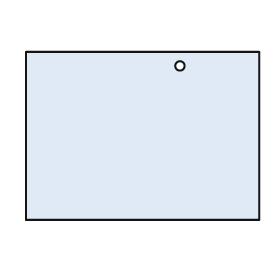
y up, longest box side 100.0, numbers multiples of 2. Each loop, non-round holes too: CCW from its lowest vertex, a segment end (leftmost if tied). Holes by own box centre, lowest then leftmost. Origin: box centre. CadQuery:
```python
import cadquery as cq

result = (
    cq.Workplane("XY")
    .moveTo(-50.0, -36.0)
    .lineTo(50.0, -36.0)
    .lineTo(50.0, 36.0)
    .lineTo(-50.0, 36.0)
    .close()
    .moveTo(16.0, 30.0)
    .circle(2.0)
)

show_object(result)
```